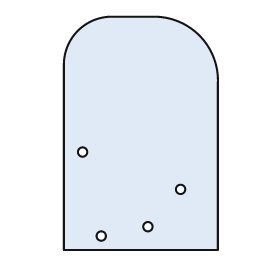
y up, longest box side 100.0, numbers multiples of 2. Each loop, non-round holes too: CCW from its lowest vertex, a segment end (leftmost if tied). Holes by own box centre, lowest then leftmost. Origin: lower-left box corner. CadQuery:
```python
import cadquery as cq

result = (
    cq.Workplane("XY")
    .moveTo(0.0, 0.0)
    .lineTo(66.0, 0.0)
    .lineTo(66.0, 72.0)
    .threePointArc((58.0, 92.0), (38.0, 100.0))
    .lineTo(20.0, 100.0)
    .threePointArc((6.0, 94.0), (0.0, 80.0))
    .close()
    .moveTo(16.0, 6.0)
    .circle(2.0)
    .moveTo(36.0, 10.0)
    .circle(2.0)
    .moveTo(50.0, 26.0)
    .circle(2.0)
    .moveTo(8.0, 42.0)
    .circle(2.0)
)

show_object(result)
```